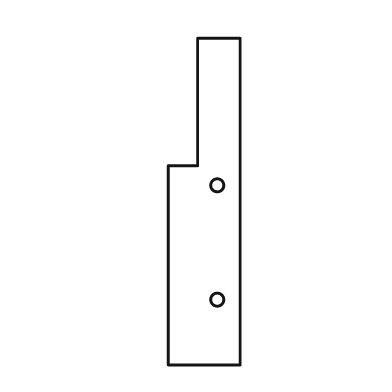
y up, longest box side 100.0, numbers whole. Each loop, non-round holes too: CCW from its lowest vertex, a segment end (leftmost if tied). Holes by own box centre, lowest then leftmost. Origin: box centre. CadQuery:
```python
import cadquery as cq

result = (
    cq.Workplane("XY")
    .moveTo(-11.0, -50.0)
    .lineTo(11.0, -50.0)
    .lineTo(11.0, 50.0)
    .lineTo(-2.0, 50.0)
    .lineTo(-2.0, 11.0)
    .lineTo(-11.0, 11.0)
    .close()
    .moveTo(4.0, -30.0)
    .circle(2.0)
    .moveTo(4.0, 5.0)
    .circle(2.0)
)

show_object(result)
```